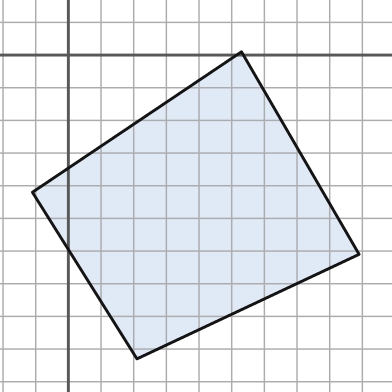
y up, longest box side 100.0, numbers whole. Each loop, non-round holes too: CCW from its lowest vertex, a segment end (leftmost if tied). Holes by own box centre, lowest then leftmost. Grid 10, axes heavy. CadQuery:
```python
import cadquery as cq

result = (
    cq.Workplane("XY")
    .moveTo(21.0, -93.0)
    .lineTo(89.0, -61.0)
    .lineTo(53.0, 1.0)
    .lineTo(-11.0, -42.0)
    .close()
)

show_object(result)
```